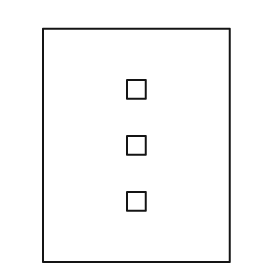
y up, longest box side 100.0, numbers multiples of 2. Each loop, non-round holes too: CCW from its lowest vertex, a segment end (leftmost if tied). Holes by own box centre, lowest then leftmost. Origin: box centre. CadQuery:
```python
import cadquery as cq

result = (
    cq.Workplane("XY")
    .moveTo(-40.0, -50.0)
    .lineTo(40.0, -50.0)
    .lineTo(40.0, 50.0)
    .lineTo(-40.0, 50.0)
    .close()
    .moveTo(-4.0, -28.0)
    .lineTo(4.0, -28.0)
    .lineTo(4.0, -20.0)
    .lineTo(-4.0, -20.0)
    .close()
    .moveTo(-4.0, -4.0)
    .lineTo(4.0, -4.0)
    .lineTo(4.0, 4.0)
    .lineTo(-4.0, 4.0)
    .close()
    .moveTo(-4.0, 20.0)
    .lineTo(4.0, 20.0)
    .lineTo(4.0, 28.0)
    .lineTo(-4.0, 28.0)
    .close()
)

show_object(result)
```